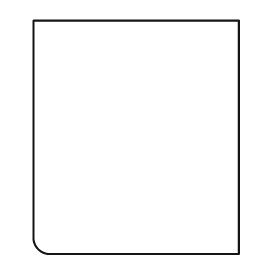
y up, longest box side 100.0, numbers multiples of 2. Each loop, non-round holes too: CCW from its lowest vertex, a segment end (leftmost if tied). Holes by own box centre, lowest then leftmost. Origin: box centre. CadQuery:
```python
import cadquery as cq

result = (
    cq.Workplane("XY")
    .moveTo(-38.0, -50.0)
    .lineTo(44.0, -50.0)
    .lineTo(44.0, 50.0)
    .lineTo(-44.0, 50.0)
    .lineTo(-44.0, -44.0)
    .threePointArc((-42.0, -48.0), (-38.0, -50.0))
    .close()
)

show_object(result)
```